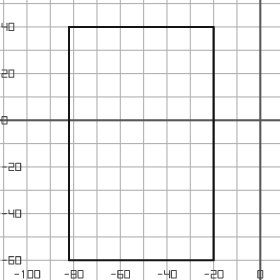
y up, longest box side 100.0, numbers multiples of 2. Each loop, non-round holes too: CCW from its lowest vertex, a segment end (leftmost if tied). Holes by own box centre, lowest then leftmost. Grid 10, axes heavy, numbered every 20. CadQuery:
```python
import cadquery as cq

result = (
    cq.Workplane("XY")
    .moveTo(-82.0, -60.0)
    .lineTo(-20.0, -60.0)
    .lineTo(-20.0, 40.0)
    .lineTo(-82.0, 40.0)
    .close()
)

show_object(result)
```